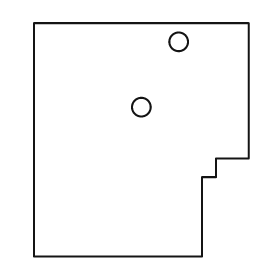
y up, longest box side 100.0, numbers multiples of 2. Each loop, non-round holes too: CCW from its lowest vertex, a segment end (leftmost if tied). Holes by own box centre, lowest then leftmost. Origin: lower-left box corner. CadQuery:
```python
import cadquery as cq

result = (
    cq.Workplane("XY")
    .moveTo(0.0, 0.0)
    .lineTo(72.0, 0.0)
    .lineTo(72.0, 34.0)
    .lineTo(78.0, 34.0)
    .lineTo(78.0, 42.0)
    .lineTo(92.0, 42.0)
    .lineTo(92.0, 100.0)
    .lineTo(0.0, 100.0)
    .close()
    .moveTo(46.0, 64.0)
    .circle(4.0)
    .moveTo(62.0, 92.0)
    .circle(4.0)
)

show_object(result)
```